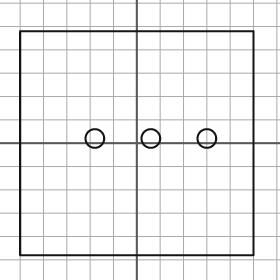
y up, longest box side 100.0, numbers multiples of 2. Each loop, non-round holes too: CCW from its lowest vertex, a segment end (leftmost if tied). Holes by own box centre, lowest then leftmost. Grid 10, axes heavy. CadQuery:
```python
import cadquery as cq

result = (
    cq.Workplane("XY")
    .moveTo(-50.0, -48.0)
    .lineTo(50.0, -48.0)
    .lineTo(50.0, 48.0)
    .lineTo(-50.0, 48.0)
    .close()
    .moveTo(-18.0, 2.0)
    .circle(4.0)
    .moveTo(6.0, 2.0)
    .circle(4.0)
    .moveTo(30.0, 2.0)
    .circle(4.0)
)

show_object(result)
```